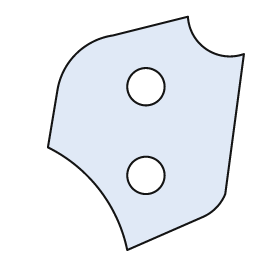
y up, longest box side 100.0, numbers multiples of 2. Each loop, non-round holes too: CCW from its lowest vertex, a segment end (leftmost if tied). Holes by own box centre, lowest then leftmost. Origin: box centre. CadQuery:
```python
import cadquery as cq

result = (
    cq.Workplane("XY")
    .moveTo(-8.0, -50.0)
    .lineTo(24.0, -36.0)
    .threePointArc((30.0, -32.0), (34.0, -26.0))
    .lineTo(42.0, 34.0)
    .threePointArc((26.0, 36.0), (18.0, 50.0))
    .lineTo(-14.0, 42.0)
    .threePointArc((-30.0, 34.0), (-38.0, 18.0))
    .lineTo(-42.0, -6.0)
    .threePointArc((-20.0, -24.0), (-8.0, -50.0))
    .close()
    .moveTo(0.0, -18.0)
    .circle(8.0)
    .moveTo(0.0, 20.0)
    .circle(8.0)
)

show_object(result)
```